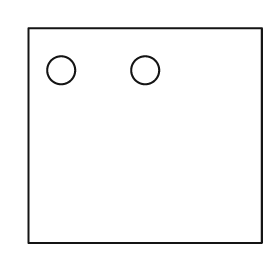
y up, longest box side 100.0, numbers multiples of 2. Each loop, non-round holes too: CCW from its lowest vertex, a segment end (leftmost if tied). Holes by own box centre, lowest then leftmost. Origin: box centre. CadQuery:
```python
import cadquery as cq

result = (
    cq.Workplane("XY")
    .moveTo(-50.0, -46.0)
    .lineTo(50.0, -46.0)
    .lineTo(50.0, 46.0)
    .lineTo(-50.0, 46.0)
    .close()
    .moveTo(-36.0, 28.0)
    .circle(6.0)
    .moveTo(0.0, 28.0)
    .circle(6.0)
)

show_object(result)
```